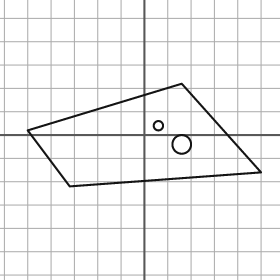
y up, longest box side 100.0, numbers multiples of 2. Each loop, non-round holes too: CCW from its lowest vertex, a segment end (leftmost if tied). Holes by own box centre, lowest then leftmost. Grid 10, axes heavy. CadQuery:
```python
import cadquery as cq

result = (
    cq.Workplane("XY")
    .moveTo(-32.0, -22.0)
    .lineTo(50.0, -16.0)
    .lineTo(16.0, 22.0)
    .lineTo(-50.0, 2.0)
    .close()
    .moveTo(16.0, -4.0)
    .circle(4.0)
    .moveTo(6.0, 4.0)
    .circle(2.0)
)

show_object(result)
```